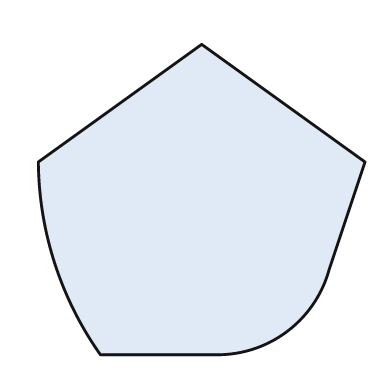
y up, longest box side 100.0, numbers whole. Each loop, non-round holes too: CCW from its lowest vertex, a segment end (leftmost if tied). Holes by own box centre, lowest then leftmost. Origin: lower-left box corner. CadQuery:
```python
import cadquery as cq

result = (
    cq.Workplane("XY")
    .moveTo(19.0, 0.0)
    .lineTo(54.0, 0.0)
    .threePointArc((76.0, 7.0), (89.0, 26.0))
    .lineTo(100.0, 59.0)
    .lineTo(50.0, 95.0)
    .lineTo(0.0, 59.0)
    .threePointArc((5.0, 28.0), (19.0, 0.0))
    .close()
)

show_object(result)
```